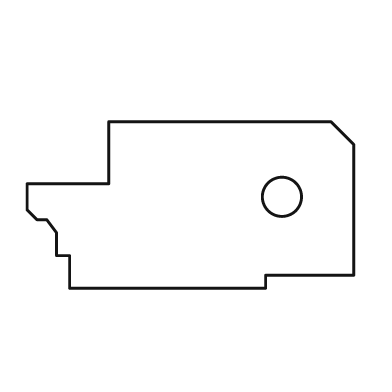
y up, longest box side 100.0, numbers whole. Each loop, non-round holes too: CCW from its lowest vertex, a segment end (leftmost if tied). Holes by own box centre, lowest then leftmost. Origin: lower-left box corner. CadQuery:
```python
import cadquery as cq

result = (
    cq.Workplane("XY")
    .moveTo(13.0, 0.0)
    .lineTo(73.0, 0.0)
    .lineTo(73.0, 4.0)
    .lineTo(100.0, 4.0)
    .lineTo(100.0, 44.0)
    .lineTo(93.0, 51.0)
    .lineTo(25.0, 51.0)
    .lineTo(25.0, 32.0)
    .lineTo(0.0, 32.0)
    .lineTo(0.0, 24.0)
    .lineTo(3.0, 21.0)
    .lineTo(6.0, 21.0)
    .lineTo(9.0, 17.0)
    .lineTo(9.0, 10.0)
    .lineTo(13.0, 10.0)
    .close()
    .moveTo(78.0, 28.0)
    .circle(6.0)
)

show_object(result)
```